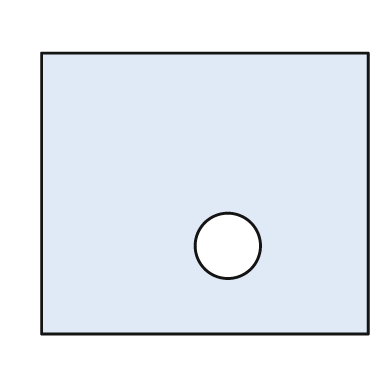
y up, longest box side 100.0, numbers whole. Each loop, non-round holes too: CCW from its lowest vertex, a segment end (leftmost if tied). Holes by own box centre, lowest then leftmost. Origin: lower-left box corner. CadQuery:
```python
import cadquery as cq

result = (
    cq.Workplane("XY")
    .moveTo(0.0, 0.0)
    .lineTo(100.0, 0.0)
    .lineTo(100.0, 86.0)
    .lineTo(0.0, 86.0)
    .close()
    .moveTo(57.0, 27.0)
    .circle(10.0)
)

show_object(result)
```